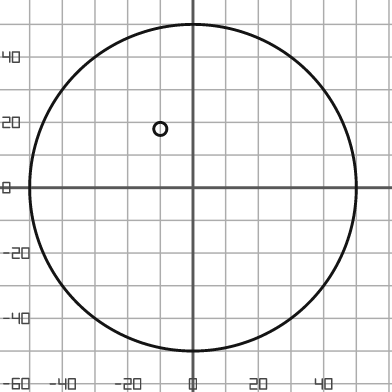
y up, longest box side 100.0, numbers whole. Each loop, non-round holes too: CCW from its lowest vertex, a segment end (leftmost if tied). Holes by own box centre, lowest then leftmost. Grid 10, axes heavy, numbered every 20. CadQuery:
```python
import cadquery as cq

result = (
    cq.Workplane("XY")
    .moveTo(0.0, 0.0)
    .circle(50.0)
    .moveTo(-10.0, 18.0)
    .circle(2.0)
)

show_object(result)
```